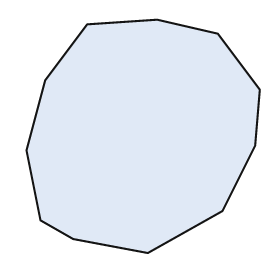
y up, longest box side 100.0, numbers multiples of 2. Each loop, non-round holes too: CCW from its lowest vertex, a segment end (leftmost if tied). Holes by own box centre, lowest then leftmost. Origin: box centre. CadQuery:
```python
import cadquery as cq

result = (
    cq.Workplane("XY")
    .moveTo(2.0, -50.0)
    .lineTo(34.0, -32.0)
    .lineTo(48.0, -4.0)
    .lineTo(50.0, 20.0)
    .lineTo(32.0, 44.0)
    .lineTo(6.0, 50.0)
    .lineTo(-24.0, 48.0)
    .lineTo(-42.0, 24.0)
    .lineTo(-50.0, -6.0)
    .lineTo(-44.0, -36.0)
    .lineTo(-30.0, -44.0)
    .close()
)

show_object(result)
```